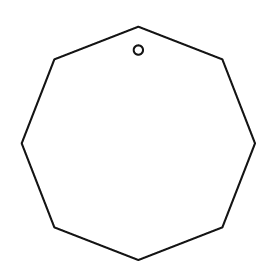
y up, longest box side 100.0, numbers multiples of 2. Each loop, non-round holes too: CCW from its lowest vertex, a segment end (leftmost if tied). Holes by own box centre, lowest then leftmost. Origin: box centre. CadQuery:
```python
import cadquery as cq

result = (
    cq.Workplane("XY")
    .moveTo(0.0, -50.0)
    .lineTo(36.0, -36.0)
    .lineTo(50.0, 0.0)
    .lineTo(36.0, 36.0)
    .lineTo(0.0, 50.0)
    .lineTo(-36.0, 36.0)
    .lineTo(-50.0, 0.0)
    .lineTo(-36.0, -36.0)
    .close()
    .moveTo(0.0, 40.0)
    .circle(2.0)
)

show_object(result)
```